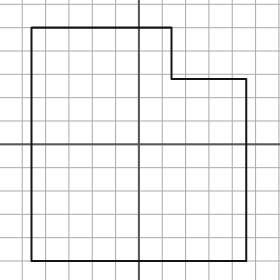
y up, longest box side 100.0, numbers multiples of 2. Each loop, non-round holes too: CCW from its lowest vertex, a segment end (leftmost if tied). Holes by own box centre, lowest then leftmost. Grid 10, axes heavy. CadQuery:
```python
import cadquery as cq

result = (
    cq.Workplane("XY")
    .moveTo(-46.0, -50.0)
    .lineTo(46.0, -50.0)
    .lineTo(46.0, 28.0)
    .lineTo(14.0, 28.0)
    .lineTo(14.0, 50.0)
    .lineTo(-46.0, 50.0)
    .close()
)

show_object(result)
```